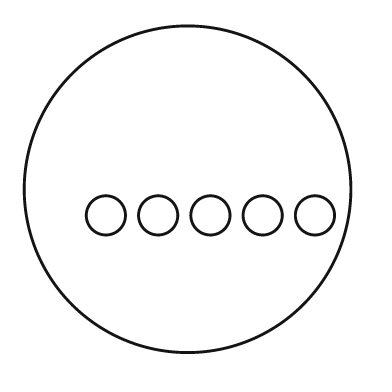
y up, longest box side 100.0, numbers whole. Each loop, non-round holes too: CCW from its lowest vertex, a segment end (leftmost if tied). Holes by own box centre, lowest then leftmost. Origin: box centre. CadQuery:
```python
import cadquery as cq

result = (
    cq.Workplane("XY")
    .moveTo(0.0, 0.0)
    .circle(50.0)
    .moveTo(-25.0, -8.0)
    .circle(6.0)
    .moveTo(-9.0, -8.0)
    .circle(6.0)
    .moveTo(7.0, -8.0)
    .circle(6.0)
    .moveTo(23.0, -8.0)
    .circle(6.0)
    .moveTo(39.0, -8.0)
    .circle(6.0)
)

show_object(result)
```